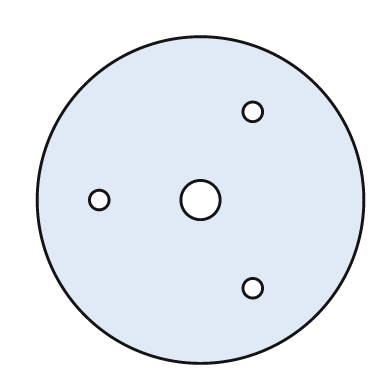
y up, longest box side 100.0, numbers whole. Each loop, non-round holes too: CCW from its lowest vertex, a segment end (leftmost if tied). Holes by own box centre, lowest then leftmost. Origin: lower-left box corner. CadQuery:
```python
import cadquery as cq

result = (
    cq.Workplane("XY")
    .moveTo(50.0, 50.0)
    .circle(50.0)
    .moveTo(66.0, 23.0)
    .circle(3.0)
    .moveTo(19.0, 50.0)
    .circle(3.0)
    .moveTo(50.0, 50.0)
    .circle(6.0)
    .moveTo(66.0, 77.0)
    .circle(3.0)
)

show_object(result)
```